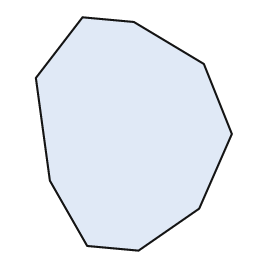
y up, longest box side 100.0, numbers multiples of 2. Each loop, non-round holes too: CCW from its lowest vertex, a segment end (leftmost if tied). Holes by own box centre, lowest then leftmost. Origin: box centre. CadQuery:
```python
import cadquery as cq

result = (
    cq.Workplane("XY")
    .moveTo(2.0, -50.0)
    .lineTo(28.0, -32.0)
    .lineTo(42.0, 0.0)
    .lineTo(30.0, 30.0)
    .lineTo(0.0, 48.0)
    .lineTo(-22.0, 50.0)
    .lineTo(-42.0, 24.0)
    .lineTo(-36.0, -20.0)
    .lineTo(-20.0, -48.0)
    .close()
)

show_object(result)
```